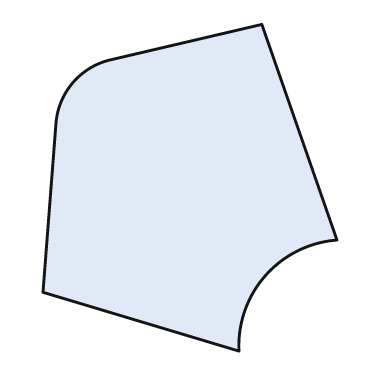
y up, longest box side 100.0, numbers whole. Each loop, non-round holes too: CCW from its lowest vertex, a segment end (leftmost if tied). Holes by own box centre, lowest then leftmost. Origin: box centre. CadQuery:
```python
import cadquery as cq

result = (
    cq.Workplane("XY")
    .moveTo(15.0, -50.0)
    .threePointArc((23.0, -27.0), (45.0, -16.0))
    .lineTo(22.0, 50.0)
    .lineTo(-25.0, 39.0)
    .threePointArc((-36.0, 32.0), (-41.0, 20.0))
    .lineTo(-45.0, -32.0)
    .close()
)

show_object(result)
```